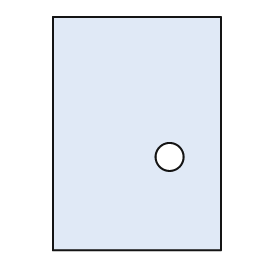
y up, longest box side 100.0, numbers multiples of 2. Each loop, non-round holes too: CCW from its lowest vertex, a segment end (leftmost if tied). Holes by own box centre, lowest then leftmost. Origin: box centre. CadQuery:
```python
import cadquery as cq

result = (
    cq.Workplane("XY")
    .moveTo(-36.0, -50.0)
    .lineTo(36.0, -50.0)
    .lineTo(36.0, 50.0)
    .lineTo(-36.0, 50.0)
    .close()
    .moveTo(14.0, -10.0)
    .circle(6.0)
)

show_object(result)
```